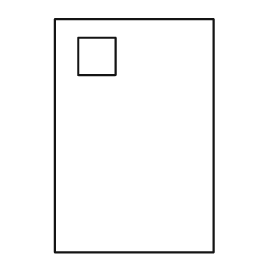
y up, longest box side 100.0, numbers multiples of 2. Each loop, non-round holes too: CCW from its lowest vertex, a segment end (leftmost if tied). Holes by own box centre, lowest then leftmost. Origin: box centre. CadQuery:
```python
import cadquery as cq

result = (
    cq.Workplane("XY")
    .moveTo(-34.0, -50.0)
    .lineTo(34.0, -50.0)
    .lineTo(34.0, 50.0)
    .lineTo(-34.0, 50.0)
    .close()
    .moveTo(-24.0, 26.0)
    .lineTo(-8.0, 26.0)
    .lineTo(-8.0, 42.0)
    .lineTo(-24.0, 42.0)
    .close()
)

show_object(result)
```